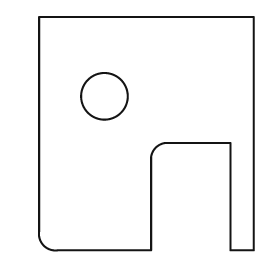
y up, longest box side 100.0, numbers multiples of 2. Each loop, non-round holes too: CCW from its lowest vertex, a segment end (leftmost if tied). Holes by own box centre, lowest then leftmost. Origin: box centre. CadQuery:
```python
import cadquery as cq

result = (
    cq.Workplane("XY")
    .moveTo(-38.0, -50.0)
    .lineTo(2.0, -50.0)
    .lineTo(2.0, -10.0)
    .threePointArc((4.0, -6.0), (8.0, -4.0))
    .lineTo(36.0, -4.0)
    .lineTo(36.0, -50.0)
    .lineTo(46.0, -50.0)
    .lineTo(46.0, 50.0)
    .lineTo(-46.0, 50.0)
    .lineTo(-46.0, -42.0)
    .threePointArc((-44.0, -48.0), (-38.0, -50.0))
    .close()
    .moveTo(-18.0, 16.0)
    .circle(10.0)
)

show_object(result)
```